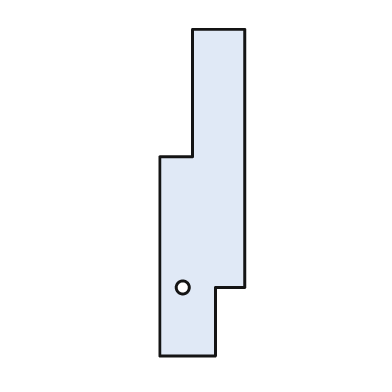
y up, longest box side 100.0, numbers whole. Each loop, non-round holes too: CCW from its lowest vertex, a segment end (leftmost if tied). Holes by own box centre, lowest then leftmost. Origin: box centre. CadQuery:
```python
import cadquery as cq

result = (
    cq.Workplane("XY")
    .moveTo(-13.0, -50.0)
    .lineTo(4.0, -50.0)
    .lineTo(4.0, -29.0)
    .lineTo(13.0, -29.0)
    .lineTo(13.0, 50.0)
    .lineTo(-3.0, 50.0)
    .lineTo(-3.0, 11.0)
    .lineTo(-13.0, 11.0)
    .close()
    .moveTo(-6.0, -29.0)
    .circle(2.0)
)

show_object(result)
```